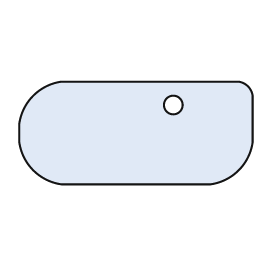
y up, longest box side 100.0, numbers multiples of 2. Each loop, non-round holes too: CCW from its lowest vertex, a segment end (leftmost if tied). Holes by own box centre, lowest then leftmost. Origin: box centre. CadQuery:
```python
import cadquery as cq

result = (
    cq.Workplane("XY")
    .moveTo(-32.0, -22.0)
    .lineTo(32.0, -22.0)
    .threePointArc((44.0, -16.0), (50.0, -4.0))
    .lineTo(50.0, 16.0)
    .threePointArc((48.0, 20.0), (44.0, 22.0))
    .lineTo(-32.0, 22.0)
    .threePointArc((-44.0, 16.0), (-50.0, 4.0))
    .lineTo(-50.0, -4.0)
    .threePointArc((-44.0, -16.0), (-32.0, -22.0))
    .close()
    .moveTo(16.0, 12.0)
    .circle(4.0)
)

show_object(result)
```